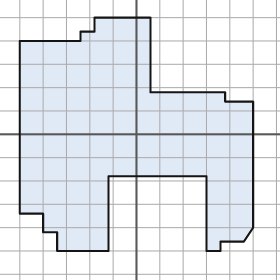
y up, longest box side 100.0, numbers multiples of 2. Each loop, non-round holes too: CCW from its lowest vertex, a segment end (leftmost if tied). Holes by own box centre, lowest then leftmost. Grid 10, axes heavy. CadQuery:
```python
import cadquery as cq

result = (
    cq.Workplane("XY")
    .moveTo(-34.0, -50.0)
    .lineTo(-12.0, -50.0)
    .lineTo(-12.0, -18.0)
    .lineTo(30.0, -18.0)
    .lineTo(30.0, -50.0)
    .lineTo(36.0, -50.0)
    .lineTo(36.0, -46.0)
    .lineTo(46.0, -46.0)
    .lineTo(50.0, -40.0)
    .lineTo(50.0, 14.0)
    .lineTo(38.0, 14.0)
    .lineTo(38.0, 18.0)
    .lineTo(6.0, 18.0)
    .lineTo(6.0, 50.0)
    .lineTo(-18.0, 50.0)
    .lineTo(-18.0, 44.0)
    .lineTo(-24.0, 44.0)
    .lineTo(-24.0, 40.0)
    .lineTo(-50.0, 40.0)
    .lineTo(-50.0, -34.0)
    .lineTo(-40.0, -34.0)
    .lineTo(-40.0, -42.0)
    .lineTo(-34.0, -42.0)
    .close()
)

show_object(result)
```